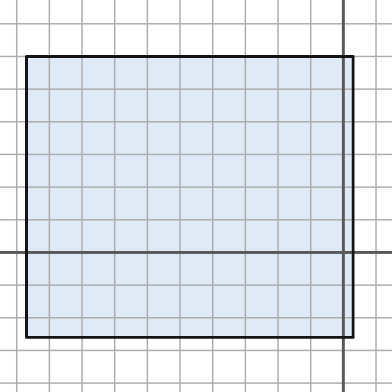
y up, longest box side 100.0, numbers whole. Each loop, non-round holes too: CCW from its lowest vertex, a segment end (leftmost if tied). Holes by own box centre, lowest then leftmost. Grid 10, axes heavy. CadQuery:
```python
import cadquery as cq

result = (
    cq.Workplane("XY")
    .moveTo(-97.0, -26.0)
    .lineTo(3.0, -26.0)
    .lineTo(3.0, 60.0)
    .lineTo(-97.0, 60.0)
    .close()
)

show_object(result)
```